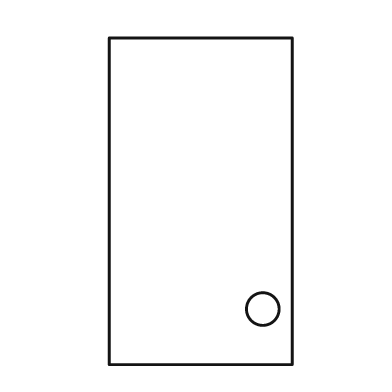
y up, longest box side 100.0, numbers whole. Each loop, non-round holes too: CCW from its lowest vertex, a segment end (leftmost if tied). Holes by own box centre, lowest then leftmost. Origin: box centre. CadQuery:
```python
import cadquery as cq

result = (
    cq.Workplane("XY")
    .moveTo(-28.0, -50.0)
    .lineTo(28.0, -50.0)
    .lineTo(28.0, 50.0)
    .lineTo(-28.0, 50.0)
    .close()
    .moveTo(19.0, -33.0)
    .circle(5.0)
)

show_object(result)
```